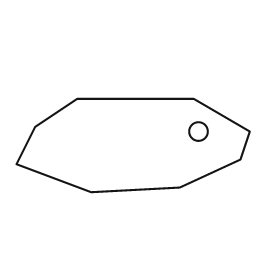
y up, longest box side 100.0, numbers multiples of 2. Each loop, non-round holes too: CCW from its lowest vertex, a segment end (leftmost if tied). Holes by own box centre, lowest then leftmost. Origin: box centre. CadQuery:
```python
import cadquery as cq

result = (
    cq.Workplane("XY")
    .moveTo(-18.0, -20.0)
    .lineTo(20.0, -18.0)
    .lineTo(46.0, -6.0)
    .lineTo(50.0, 6.0)
    .lineTo(26.0, 20.0)
    .lineTo(-24.0, 20.0)
    .lineTo(-42.0, 8.0)
    .lineTo(-50.0, -8.0)
    .close()
    .moveTo(28.0, 6.0)
    .circle(4.0)
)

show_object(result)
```